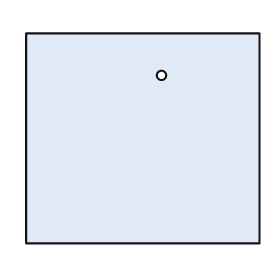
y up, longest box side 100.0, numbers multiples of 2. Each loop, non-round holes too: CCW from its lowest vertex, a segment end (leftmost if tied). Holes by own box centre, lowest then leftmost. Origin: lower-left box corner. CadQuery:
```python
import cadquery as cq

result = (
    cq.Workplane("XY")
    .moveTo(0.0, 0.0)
    .lineTo(100.0, 0.0)
    .lineTo(100.0, 90.0)
    .lineTo(0.0, 90.0)
    .close()
    .moveTo(58.0, 72.0)
    .circle(2.0)
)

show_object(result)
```